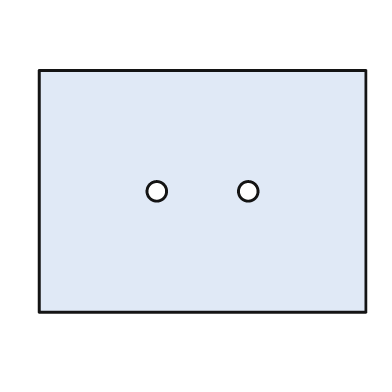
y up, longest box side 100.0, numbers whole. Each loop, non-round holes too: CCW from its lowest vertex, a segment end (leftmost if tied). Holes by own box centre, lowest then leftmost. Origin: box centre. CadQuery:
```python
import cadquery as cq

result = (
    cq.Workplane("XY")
    .moveTo(-50.0, -37.0)
    .lineTo(50.0, -37.0)
    .lineTo(50.0, 37.0)
    .lineTo(-50.0, 37.0)
    .close()
    .moveTo(-14.0, 0.0)
    .circle(3.0)
    .moveTo(14.0, 0.0)
    .circle(3.0)
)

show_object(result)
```